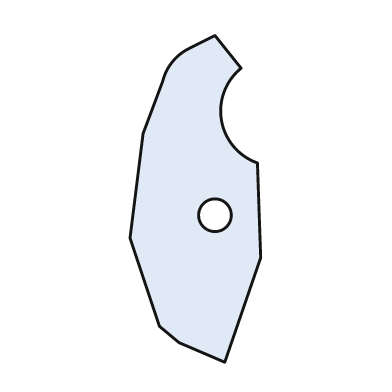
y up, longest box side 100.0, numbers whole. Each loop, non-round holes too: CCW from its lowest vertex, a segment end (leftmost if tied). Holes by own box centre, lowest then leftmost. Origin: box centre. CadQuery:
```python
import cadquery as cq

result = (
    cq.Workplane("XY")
    .moveTo(9.0, -50.0)
    .lineTo(20.0, -18.0)
    .lineTo(19.0, 11.0)
    .threePointArc((8.0, 24.0), (14.0, 40.0))
    .lineTo(6.0, 50.0)
    .lineTo(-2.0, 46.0)
    .threePointArc((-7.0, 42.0), (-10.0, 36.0))
    .lineTo(-16.0, 20.0)
    .lineTo(-20.0, -12.0)
    .lineTo(-11.0, -39.0)
    .lineTo(-5.0, -44.0)
    .close()
    .moveTo(6.0, -5.0)
    .circle(5.0)
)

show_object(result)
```